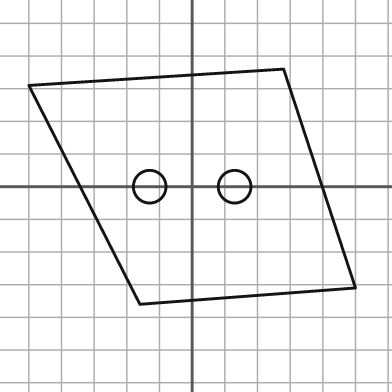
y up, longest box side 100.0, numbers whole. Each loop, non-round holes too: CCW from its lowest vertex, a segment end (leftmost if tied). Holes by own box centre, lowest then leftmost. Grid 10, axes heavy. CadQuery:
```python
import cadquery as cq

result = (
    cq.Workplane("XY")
    .moveTo(-16.0, -36.0)
    .lineTo(50.0, -31.0)
    .lineTo(28.0, 36.0)
    .lineTo(-50.0, 31.0)
    .close()
    .moveTo(-13.0, 0.0)
    .circle(5.0)
    .moveTo(13.0, 0.0)
    .circle(5.0)
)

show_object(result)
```